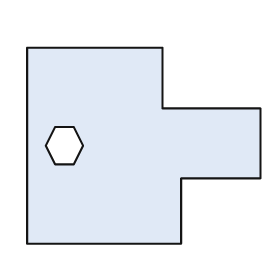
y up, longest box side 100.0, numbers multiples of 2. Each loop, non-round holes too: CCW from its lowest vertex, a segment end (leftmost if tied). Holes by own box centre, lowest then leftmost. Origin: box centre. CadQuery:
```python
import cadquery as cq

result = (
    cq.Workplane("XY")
    .moveTo(-50.0, -42.0)
    .lineTo(16.0, -42.0)
    .lineTo(16.0, -14.0)
    .lineTo(50.0, -14.0)
    .lineTo(50.0, 16.0)
    .lineTo(8.0, 16.0)
    .lineTo(8.0, 42.0)
    .lineTo(-50.0, 42.0)
    .close()
    .moveTo(-38.0, -8.0)
    .lineTo(-30.0, -8.0)
    .lineTo(-26.0, 0.0)
    .lineTo(-30.0, 8.0)
    .lineTo(-38.0, 8.0)
    .lineTo(-42.0, 0.0)
    .close()
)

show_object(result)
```